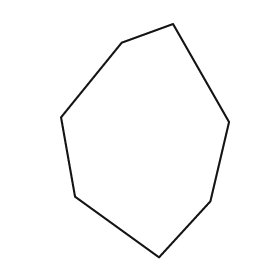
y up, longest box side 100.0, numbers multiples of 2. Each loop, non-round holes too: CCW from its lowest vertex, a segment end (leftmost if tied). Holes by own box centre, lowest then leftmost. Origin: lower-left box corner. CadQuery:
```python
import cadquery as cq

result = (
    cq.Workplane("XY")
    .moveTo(42.0, 0.0)
    .lineTo(64.0, 24.0)
    .lineTo(72.0, 58.0)
    .lineTo(48.0, 100.0)
    .lineTo(26.0, 92.0)
    .lineTo(0.0, 60.0)
    .lineTo(6.0, 26.0)
    .close()
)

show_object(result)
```